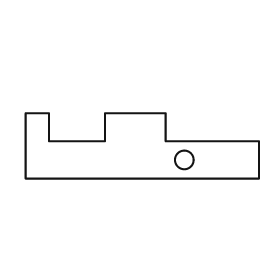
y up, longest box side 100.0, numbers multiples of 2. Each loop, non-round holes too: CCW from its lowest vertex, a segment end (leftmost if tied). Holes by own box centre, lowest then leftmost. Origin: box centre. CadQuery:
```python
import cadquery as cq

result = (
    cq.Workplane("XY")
    .moveTo(-50.0, -14.0)
    .lineTo(50.0, -14.0)
    .lineTo(50.0, 2.0)
    .lineTo(10.0, 2.0)
    .lineTo(10.0, 14.0)
    .lineTo(-16.0, 14.0)
    .lineTo(-16.0, 2.0)
    .lineTo(-40.0, 2.0)
    .lineTo(-40.0, 14.0)
    .lineTo(-50.0, 14.0)
    .close()
    .moveTo(18.0, -6.0)
    .circle(4.0)
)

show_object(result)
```